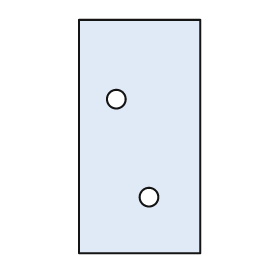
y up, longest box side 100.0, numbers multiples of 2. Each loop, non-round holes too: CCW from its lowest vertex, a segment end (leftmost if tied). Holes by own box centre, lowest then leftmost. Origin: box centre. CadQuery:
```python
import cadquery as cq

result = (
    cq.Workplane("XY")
    .moveTo(-26.0, -50.0)
    .lineTo(26.0, -50.0)
    .lineTo(26.0, 50.0)
    .lineTo(-26.0, 50.0)
    .close()
    .moveTo(4.0, -26.0)
    .circle(4.0)
    .moveTo(-10.0, 16.0)
    .circle(4.0)
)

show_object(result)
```